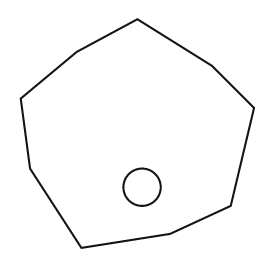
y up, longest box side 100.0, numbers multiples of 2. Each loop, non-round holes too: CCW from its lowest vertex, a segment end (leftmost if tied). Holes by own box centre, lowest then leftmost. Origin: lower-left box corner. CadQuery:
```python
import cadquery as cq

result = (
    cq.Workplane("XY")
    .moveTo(26.0, 0.0)
    .lineTo(64.0, 6.0)
    .lineTo(90.0, 18.0)
    .lineTo(100.0, 60.0)
    .lineTo(82.0, 78.0)
    .lineTo(50.0, 98.0)
    .lineTo(24.0, 84.0)
    .lineTo(0.0, 64.0)
    .lineTo(4.0, 34.0)
    .close()
    .moveTo(52.0, 26.0)
    .circle(8.0)
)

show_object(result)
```